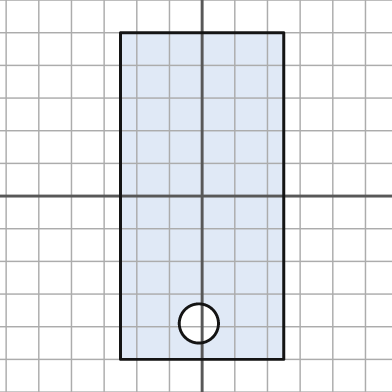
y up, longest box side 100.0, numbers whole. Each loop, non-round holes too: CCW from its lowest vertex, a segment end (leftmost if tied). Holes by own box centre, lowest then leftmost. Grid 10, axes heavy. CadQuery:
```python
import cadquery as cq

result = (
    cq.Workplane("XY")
    .moveTo(-25.0, -50.0)
    .lineTo(25.0, -50.0)
    .lineTo(25.0, 50.0)
    .lineTo(-25.0, 50.0)
    .close()
    .moveTo(-1.0, -39.0)
    .circle(6.0)
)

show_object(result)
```